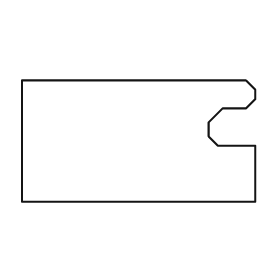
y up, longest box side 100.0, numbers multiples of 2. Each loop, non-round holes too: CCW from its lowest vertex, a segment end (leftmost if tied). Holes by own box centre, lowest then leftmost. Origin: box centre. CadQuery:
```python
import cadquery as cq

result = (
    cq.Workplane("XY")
    .moveTo(-50.0, -26.0)
    .lineTo(50.0, -26.0)
    .lineTo(50.0, -2.0)
    .lineTo(34.0, -2.0)
    .lineTo(30.0, 2.0)
    .lineTo(30.0, 8.0)
    .lineTo(36.0, 14.0)
    .lineTo(46.0, 14.0)
    .lineTo(50.0, 18.0)
    .lineTo(50.0, 22.0)
    .lineTo(46.0, 26.0)
    .lineTo(-50.0, 26.0)
    .close()
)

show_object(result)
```